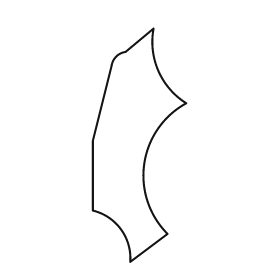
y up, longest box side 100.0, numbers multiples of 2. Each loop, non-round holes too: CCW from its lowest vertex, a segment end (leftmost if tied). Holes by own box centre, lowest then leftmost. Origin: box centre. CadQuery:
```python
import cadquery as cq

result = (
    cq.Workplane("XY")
    .moveTo(-4.0, -50.0)
    .lineTo(12.0, -38.0)
    .threePointArc((2.0, -8.0), (20.0, 18.0))
    .threePointArc((8.0, 32.0), (6.0, 50.0))
    .lineTo(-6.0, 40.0)
    .threePointArc((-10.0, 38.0), (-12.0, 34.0))
    .lineTo(-20.0, 2.0)
    .lineTo(-20.0, -28.0)
    .threePointArc((-8.0, -36.0), (-4.0, -50.0))
    .close()
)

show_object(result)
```